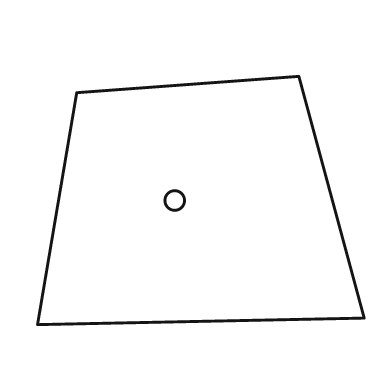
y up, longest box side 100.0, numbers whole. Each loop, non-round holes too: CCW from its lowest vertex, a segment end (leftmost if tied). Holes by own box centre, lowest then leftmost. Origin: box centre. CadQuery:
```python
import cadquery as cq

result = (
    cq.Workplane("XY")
    .moveTo(-50.0, -38.0)
    .lineTo(50.0, -36.0)
    .lineTo(30.0, 38.0)
    .lineTo(-38.0, 33.0)
    .close()
    .moveTo(-8.0, 0.0)
    .circle(3.0)
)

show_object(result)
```